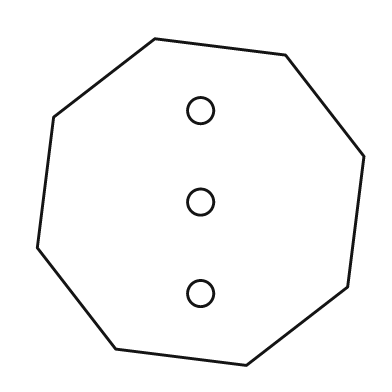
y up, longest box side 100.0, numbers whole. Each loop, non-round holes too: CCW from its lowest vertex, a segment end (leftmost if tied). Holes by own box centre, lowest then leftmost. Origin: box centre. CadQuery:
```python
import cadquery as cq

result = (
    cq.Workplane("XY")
    .moveTo(14.0, -50.0)
    .lineTo(45.0, -26.0)
    .lineTo(50.0, 14.0)
    .lineTo(26.0, 45.0)
    .lineTo(-14.0, 50.0)
    .lineTo(-45.0, 26.0)
    .lineTo(-50.0, -14.0)
    .lineTo(-26.0, -45.0)
    .close()
    .moveTo(0.0, -28.0)
    .circle(4.0)
    .moveTo(0.0, 0.0)
    .circle(4.0)
    .moveTo(0.0, 28.0)
    .circle(4.0)
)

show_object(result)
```